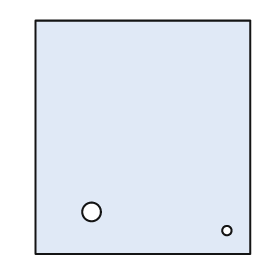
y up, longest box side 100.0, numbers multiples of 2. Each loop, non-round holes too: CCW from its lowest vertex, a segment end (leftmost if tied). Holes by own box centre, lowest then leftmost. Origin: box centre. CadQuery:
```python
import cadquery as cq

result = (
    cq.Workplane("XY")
    .moveTo(-46.0, -50.0)
    .lineTo(46.0, -50.0)
    .lineTo(46.0, 50.0)
    .lineTo(-46.0, 50.0)
    .close()
    .moveTo(36.0, -40.0)
    .circle(2.0)
    .moveTo(-22.0, -32.0)
    .circle(4.0)
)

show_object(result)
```